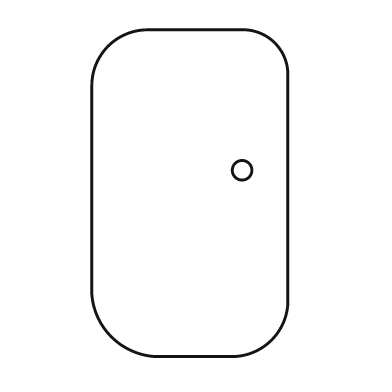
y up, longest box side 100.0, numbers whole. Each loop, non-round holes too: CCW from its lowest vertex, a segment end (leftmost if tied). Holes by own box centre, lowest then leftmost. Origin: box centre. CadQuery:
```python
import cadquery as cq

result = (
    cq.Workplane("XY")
    .moveTo(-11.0, -50.0)
    .lineTo(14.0, -50.0)
    .threePointArc((25.0, -45.0), (30.0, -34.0))
    .lineTo(30.0, 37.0)
    .threePointArc((26.0, 46.0), (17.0, 50.0))
    .lineTo(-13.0, 50.0)
    .threePointArc((-25.0, 45.0), (-30.0, 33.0))
    .lineTo(-30.0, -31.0)
    .threePointArc((-24.0, -44.0), (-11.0, -50.0))
    .close()
    .moveTo(16.0, 7.0)
    .circle(3.0)
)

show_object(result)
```